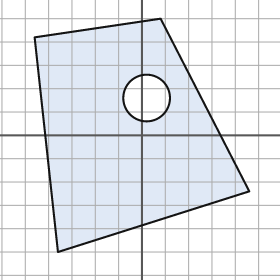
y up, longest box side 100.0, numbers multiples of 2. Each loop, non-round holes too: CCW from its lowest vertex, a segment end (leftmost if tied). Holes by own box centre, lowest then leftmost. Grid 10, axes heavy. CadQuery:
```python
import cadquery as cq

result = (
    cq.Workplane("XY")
    .moveTo(-36.0, -50.0)
    .lineTo(46.0, -24.0)
    .lineTo(8.0, 50.0)
    .lineTo(-46.0, 42.0)
    .close()
    .moveTo(2.0, 16.0)
    .circle(10.0)
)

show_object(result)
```